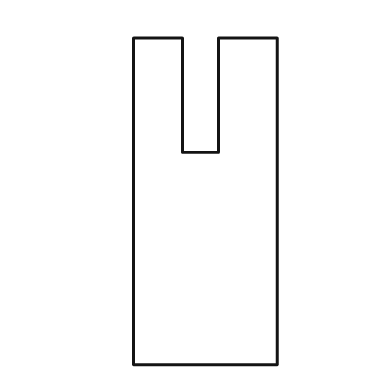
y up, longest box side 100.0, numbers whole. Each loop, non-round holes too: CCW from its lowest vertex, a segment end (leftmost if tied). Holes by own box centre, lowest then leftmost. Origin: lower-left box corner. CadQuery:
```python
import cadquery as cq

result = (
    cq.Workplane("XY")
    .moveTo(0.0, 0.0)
    .lineTo(44.0, 0.0)
    .lineTo(44.0, 100.0)
    .lineTo(26.0, 100.0)
    .lineTo(26.0, 65.0)
    .lineTo(15.0, 65.0)
    .lineTo(15.0, 100.0)
    .lineTo(0.0, 100.0)
    .close()
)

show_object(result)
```